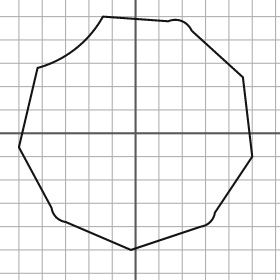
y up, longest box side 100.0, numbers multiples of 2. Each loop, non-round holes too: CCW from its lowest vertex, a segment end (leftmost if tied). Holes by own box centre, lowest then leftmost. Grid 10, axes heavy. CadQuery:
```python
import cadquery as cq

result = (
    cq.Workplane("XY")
    .moveTo(-2.0, -50.0)
    .lineTo(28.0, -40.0)
    .threePointArc((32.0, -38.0), (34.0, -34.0))
    .lineTo(50.0, -10.0)
    .lineTo(46.0, 24.0)
    .lineTo(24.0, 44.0)
    .threePointArc((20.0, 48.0), (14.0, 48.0))
    .lineTo(-14.0, 50.0)
    .threePointArc((-26.0, 36.0), (-42.0, 28.0))
    .lineTo(-50.0, -6.0)
    .lineTo(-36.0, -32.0)
    .threePointArc((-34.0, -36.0), (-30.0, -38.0))
    .close()
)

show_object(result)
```